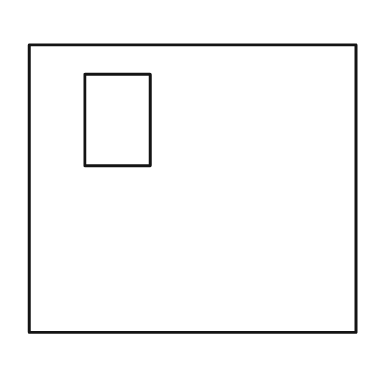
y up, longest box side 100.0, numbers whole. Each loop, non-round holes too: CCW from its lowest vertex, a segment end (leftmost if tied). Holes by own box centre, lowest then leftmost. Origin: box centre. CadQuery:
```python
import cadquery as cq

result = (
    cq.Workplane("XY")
    .moveTo(-50.0, -44.0)
    .lineTo(50.0, -44.0)
    .lineTo(50.0, 44.0)
    .lineTo(-50.0, 44.0)
    .close()
    .moveTo(-33.0, 7.0)
    .lineTo(-13.0, 7.0)
    .lineTo(-13.0, 35.0)
    .lineTo(-33.0, 35.0)
    .close()
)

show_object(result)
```